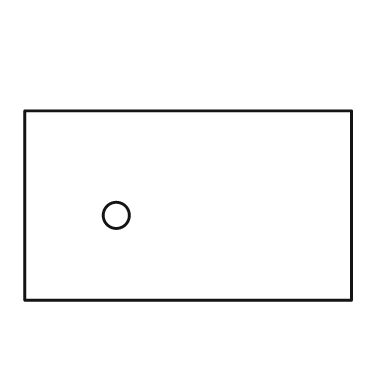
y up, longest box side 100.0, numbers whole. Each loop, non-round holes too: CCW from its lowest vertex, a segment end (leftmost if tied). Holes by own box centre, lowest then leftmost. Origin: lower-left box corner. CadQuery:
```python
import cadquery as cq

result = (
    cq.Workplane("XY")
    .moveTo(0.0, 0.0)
    .lineTo(100.0, 0.0)
    .lineTo(100.0, 58.0)
    .lineTo(0.0, 58.0)
    .close()
    .moveTo(28.0, 26.0)
    .circle(4.0)
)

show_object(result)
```